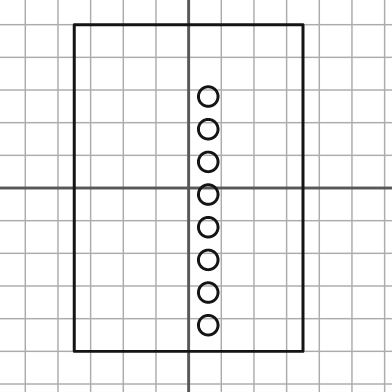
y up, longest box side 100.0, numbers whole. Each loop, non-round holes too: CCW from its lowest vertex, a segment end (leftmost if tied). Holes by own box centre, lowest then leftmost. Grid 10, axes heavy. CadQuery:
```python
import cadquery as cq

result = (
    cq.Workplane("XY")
    .moveTo(-35.0, -50.0)
    .lineTo(35.0, -50.0)
    .lineTo(35.0, 50.0)
    .lineTo(-35.0, 50.0)
    .close()
    .moveTo(6.0, -42.0)
    .circle(3.0)
    .moveTo(6.0, -32.0)
    .circle(3.0)
    .moveTo(6.0, -22.0)
    .circle(3.0)
    .moveTo(6.0, -12.0)
    .circle(3.0)
    .moveTo(6.0, -2.0)
    .circle(3.0)
    .moveTo(6.0, 8.0)
    .circle(3.0)
    .moveTo(6.0, 18.0)
    .circle(3.0)
    .moveTo(6.0, 28.0)
    .circle(3.0)
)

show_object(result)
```